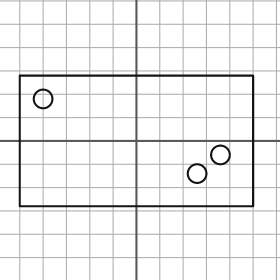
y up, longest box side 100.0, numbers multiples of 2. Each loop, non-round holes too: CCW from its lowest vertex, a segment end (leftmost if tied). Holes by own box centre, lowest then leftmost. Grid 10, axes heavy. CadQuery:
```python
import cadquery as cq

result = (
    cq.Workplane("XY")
    .moveTo(-50.0, -28.0)
    .lineTo(50.0, -28.0)
    .lineTo(50.0, 28.0)
    .lineTo(-50.0, 28.0)
    .close()
    .moveTo(26.0, -14.0)
    .circle(4.0)
    .moveTo(36.0, -6.0)
    .circle(4.0)
    .moveTo(-40.0, 18.0)
    .circle(4.0)
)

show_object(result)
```